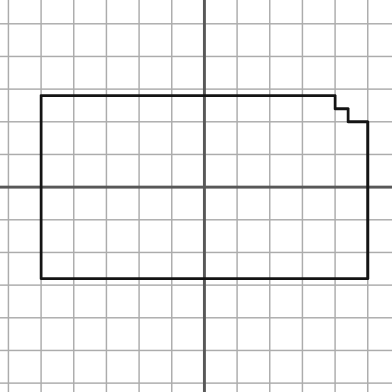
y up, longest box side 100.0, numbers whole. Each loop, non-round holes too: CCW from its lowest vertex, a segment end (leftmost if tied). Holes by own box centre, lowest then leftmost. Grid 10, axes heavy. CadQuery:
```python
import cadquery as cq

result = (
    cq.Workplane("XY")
    .moveTo(-50.0, -28.0)
    .lineTo(50.0, -28.0)
    .lineTo(50.0, 20.0)
    .lineTo(44.0, 20.0)
    .lineTo(44.0, 24.0)
    .lineTo(40.0, 24.0)
    .lineTo(40.0, 28.0)
    .lineTo(-50.0, 28.0)
    .close()
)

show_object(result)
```